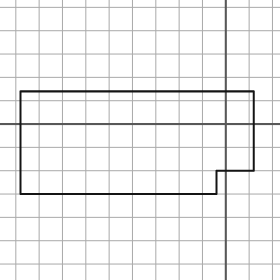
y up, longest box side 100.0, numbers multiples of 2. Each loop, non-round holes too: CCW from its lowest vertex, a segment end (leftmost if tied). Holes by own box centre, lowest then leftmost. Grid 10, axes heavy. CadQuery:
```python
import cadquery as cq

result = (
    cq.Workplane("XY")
    .moveTo(-88.0, -30.0)
    .lineTo(-4.0, -30.0)
    .lineTo(-4.0, -20.0)
    .lineTo(12.0, -20.0)
    .lineTo(12.0, 14.0)
    .lineTo(-88.0, 14.0)
    .close()
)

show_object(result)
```